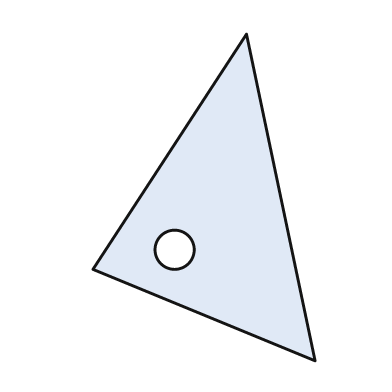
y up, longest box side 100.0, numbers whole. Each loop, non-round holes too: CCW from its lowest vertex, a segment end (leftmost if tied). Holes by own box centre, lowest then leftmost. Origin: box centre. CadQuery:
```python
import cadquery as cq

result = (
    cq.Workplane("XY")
    .moveTo(34.0, -50.0)
    .lineTo(13.0, 50.0)
    .lineTo(-34.0, -22.0)
    .close()
    .moveTo(-9.0, -16.0)
    .circle(6.0)
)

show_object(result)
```